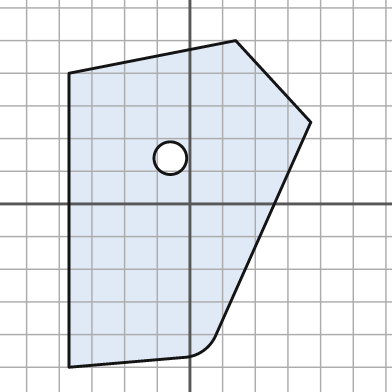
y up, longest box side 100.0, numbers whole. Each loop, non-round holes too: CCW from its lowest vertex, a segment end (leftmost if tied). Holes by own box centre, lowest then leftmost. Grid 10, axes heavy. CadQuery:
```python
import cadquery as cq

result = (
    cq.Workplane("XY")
    .moveTo(-37.0, -50.0)
    .lineTo(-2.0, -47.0)
    .threePointArc((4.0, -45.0), (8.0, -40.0))
    .lineTo(37.0, 25.0)
    .lineTo(14.0, 50.0)
    .lineTo(-37.0, 40.0)
    .close()
    .moveTo(-6.0, 14.0)
    .circle(5.0)
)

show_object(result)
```